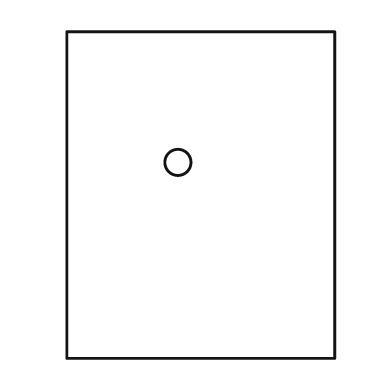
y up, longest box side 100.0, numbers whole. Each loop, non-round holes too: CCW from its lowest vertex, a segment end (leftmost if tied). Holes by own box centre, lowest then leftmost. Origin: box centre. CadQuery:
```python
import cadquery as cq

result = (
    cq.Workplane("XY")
    .moveTo(-41.0, -50.0)
    .lineTo(41.0, -50.0)
    .lineTo(41.0, 50.0)
    .lineTo(-41.0, 50.0)
    .close()
    .moveTo(-7.0, 10.0)
    .circle(4.0)
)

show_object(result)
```